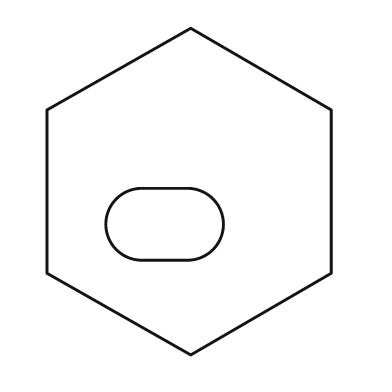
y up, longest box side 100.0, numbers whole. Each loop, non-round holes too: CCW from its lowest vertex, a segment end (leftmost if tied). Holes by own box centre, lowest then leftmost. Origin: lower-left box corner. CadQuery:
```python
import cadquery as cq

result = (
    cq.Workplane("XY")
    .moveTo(44.0, 0.0)
    .lineTo(87.0, 25.0)
    .lineTo(87.0, 75.0)
    .lineTo(44.0, 100.0)
    .lineTo(0.0, 75.0)
    .lineTo(0.0, 25.0)
    .close()
    .moveTo(29.0, 29.0)
    .lineTo(43.0, 29.0)
    .threePointArc((54.0, 40.0), (43.0, 51.0))
    .lineTo(29.0, 51.0)
    .threePointArc((18.0, 40.0), (29.0, 29.0))
    .close()
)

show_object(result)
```